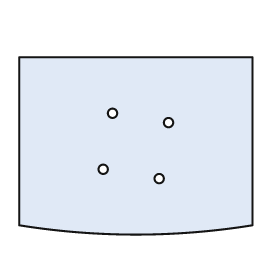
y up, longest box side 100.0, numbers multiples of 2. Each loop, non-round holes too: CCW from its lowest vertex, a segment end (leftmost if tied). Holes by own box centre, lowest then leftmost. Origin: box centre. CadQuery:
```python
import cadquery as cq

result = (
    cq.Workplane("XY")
    .moveTo(-50.0, -34.0)
    .threePointArc((0.0, -38.0), (50.0, -34.0))
    .lineTo(50.0, 38.0)
    .lineTo(-50.0, 38.0)
    .close()
    .moveTo(10.0, -14.0)
    .circle(2.0)
    .moveTo(-14.0, -10.0)
    .circle(2.0)
    .moveTo(14.0, 10.0)
    .circle(2.0)
    .moveTo(-10.0, 14.0)
    .circle(2.0)
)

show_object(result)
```